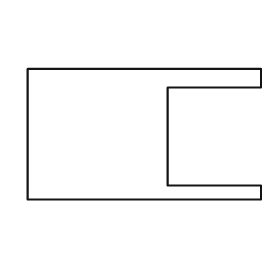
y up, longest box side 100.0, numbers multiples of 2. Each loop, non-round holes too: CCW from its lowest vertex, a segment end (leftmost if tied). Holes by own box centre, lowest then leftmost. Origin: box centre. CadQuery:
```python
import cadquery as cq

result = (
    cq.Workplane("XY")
    .moveTo(-50.0, -28.0)
    .lineTo(50.0, -28.0)
    .lineTo(50.0, -22.0)
    .lineTo(10.0, -22.0)
    .lineTo(10.0, 20.0)
    .lineTo(50.0, 20.0)
    .lineTo(50.0, 28.0)
    .lineTo(-50.0, 28.0)
    .close()
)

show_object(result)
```